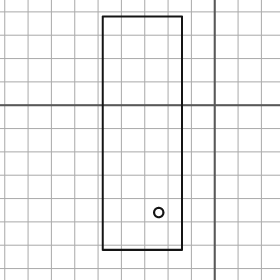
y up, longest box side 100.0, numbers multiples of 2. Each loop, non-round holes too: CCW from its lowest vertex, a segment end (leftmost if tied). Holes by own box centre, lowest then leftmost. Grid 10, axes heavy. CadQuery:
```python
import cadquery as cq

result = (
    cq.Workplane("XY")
    .moveTo(-48.0, -62.0)
    .lineTo(-14.0, -62.0)
    .lineTo(-14.0, 38.0)
    .lineTo(-48.0, 38.0)
    .close()
    .moveTo(-24.0, -46.0)
    .circle(2.0)
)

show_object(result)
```